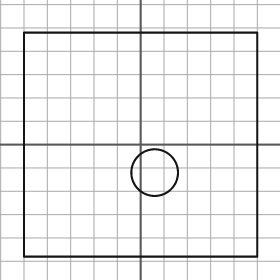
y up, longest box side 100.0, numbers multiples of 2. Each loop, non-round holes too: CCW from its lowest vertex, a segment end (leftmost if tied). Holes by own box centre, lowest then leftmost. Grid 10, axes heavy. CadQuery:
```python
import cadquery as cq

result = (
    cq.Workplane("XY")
    .moveTo(-50.0, -48.0)
    .lineTo(50.0, -48.0)
    .lineTo(50.0, 48.0)
    .lineTo(-50.0, 48.0)
    .close()
    .moveTo(6.0, -12.0)
    .circle(10.0)
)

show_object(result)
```